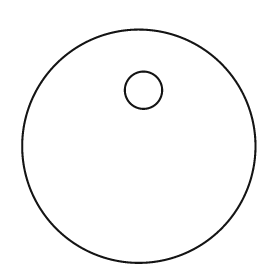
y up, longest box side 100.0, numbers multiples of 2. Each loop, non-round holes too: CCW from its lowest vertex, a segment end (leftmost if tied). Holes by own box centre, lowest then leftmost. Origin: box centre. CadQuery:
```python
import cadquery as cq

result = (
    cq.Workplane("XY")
    .moveTo(0.0, 0.0)
    .circle(50.0)
    .moveTo(2.0, 24.0)
    .circle(8.0)
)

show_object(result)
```